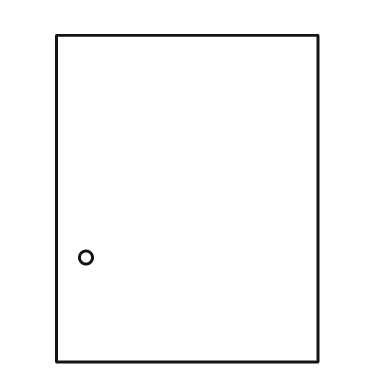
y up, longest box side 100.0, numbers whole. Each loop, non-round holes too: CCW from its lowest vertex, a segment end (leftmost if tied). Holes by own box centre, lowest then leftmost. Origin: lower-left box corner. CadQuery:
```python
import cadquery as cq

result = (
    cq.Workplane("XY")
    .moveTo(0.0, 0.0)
    .lineTo(80.0, 0.0)
    .lineTo(80.0, 100.0)
    .lineTo(0.0, 100.0)
    .close()
    .moveTo(9.0, 32.0)
    .circle(2.0)
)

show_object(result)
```